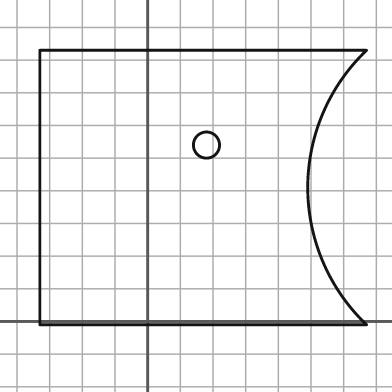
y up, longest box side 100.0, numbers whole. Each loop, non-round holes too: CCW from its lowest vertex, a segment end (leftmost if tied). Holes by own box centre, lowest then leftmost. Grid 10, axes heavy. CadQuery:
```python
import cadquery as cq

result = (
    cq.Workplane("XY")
    .moveTo(-33.0, -1.0)
    .lineTo(67.0, -1.0)
    .threePointArc((49.0, 41.0), (67.0, 83.0))
    .lineTo(-33.0, 83.0)
    .close()
    .moveTo(18.0, 54.0)
    .circle(4.0)
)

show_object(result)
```